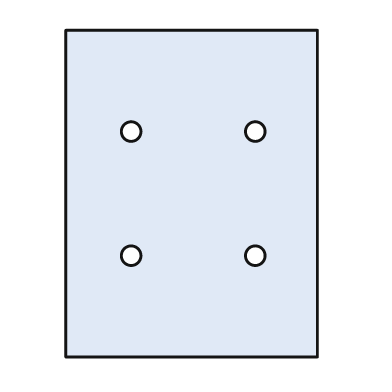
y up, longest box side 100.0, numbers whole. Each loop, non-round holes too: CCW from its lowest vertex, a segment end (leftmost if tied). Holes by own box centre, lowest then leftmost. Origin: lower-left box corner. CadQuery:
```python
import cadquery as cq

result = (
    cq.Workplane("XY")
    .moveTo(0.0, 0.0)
    .lineTo(77.0, 0.0)
    .lineTo(77.0, 100.0)
    .lineTo(0.0, 100.0)
    .close()
    .moveTo(20.0, 31.0)
    .circle(3.0)
    .moveTo(58.0, 31.0)
    .circle(3.0)
    .moveTo(20.0, 69.0)
    .circle(3.0)
    .moveTo(58.0, 69.0)
    .circle(3.0)
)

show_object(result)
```